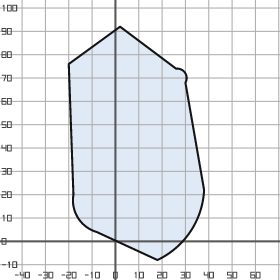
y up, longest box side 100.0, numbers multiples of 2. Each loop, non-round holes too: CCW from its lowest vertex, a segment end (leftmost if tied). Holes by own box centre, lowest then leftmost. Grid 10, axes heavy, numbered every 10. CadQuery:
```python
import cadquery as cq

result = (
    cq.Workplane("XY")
    .moveTo(18.0, -8.0)
    .threePointArc((32.0, 4.0), (38.0, 22.0))
    .lineTo(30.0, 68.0)
    .threePointArc((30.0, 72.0), (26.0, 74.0))
    .lineTo(2.0, 92.0)
    .lineTo(-20.0, 76.0)
    .lineTo(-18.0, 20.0)
    .threePointArc((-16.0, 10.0), (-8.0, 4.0))
    .close()
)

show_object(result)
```